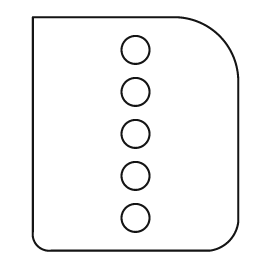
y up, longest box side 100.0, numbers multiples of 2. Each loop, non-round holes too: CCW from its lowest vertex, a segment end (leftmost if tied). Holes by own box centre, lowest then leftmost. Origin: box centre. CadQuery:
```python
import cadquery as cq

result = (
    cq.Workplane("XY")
    .moveTo(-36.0, -50.0)
    .lineTo(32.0, -50.0)
    .threePointArc((40.0, -46.0), (44.0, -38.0))
    .lineTo(44.0, 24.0)
    .threePointArc((36.0, 42.0), (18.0, 50.0))
    .lineTo(-44.0, 50.0)
    .lineTo(-44.0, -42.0)
    .threePointArc((-42.0, -48.0), (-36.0, -50.0))
    .close()
    .moveTo(0.0, -36.0)
    .circle(6.0)
    .moveTo(0.0, -18.0)
    .circle(6.0)
    .moveTo(0.0, 0.0)
    .circle(6.0)
    .moveTo(0.0, 18.0)
    .circle(6.0)
    .moveTo(0.0, 36.0)
    .circle(6.0)
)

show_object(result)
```